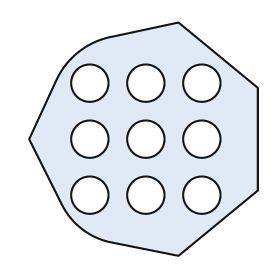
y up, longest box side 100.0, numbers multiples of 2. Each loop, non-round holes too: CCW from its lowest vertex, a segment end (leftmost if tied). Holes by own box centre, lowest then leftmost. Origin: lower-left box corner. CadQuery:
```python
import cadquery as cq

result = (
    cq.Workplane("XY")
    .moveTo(64.0, 0.0)
    .lineTo(98.0, 28.0)
    .lineTo(98.0, 72.0)
    .lineTo(64.0, 100.0)
    .lineTo(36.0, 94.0)
    .threePointArc((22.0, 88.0), (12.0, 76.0))
    .lineTo(0.0, 50.0)
    .lineTo(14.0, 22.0)
    .threePointArc((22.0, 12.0), (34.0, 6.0))
    .close()
    .moveTo(26.0, 26.0)
    .circle(8.0)
    .moveTo(50.0, 26.0)
    .circle(8.0)
    .moveTo(74.0, 26.0)
    .circle(8.0)
    .moveTo(26.0, 50.0)
    .circle(8.0)
    .moveTo(50.0, 50.0)
    .circle(8.0)
    .moveTo(74.0, 50.0)
    .circle(8.0)
    .moveTo(26.0, 74.0)
    .circle(8.0)
    .moveTo(50.0, 74.0)
    .circle(8.0)
    .moveTo(74.0, 74.0)
    .circle(8.0)
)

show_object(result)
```